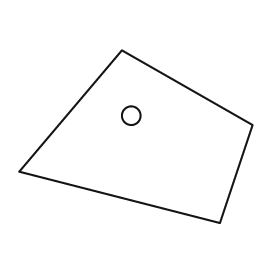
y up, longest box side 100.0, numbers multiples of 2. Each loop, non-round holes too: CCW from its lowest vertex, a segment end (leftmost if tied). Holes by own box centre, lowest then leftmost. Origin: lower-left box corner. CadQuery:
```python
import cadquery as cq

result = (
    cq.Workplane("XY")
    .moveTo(86.0, 0.0)
    .lineTo(100.0, 42.0)
    .lineTo(44.0, 74.0)
    .lineTo(0.0, 22.0)
    .close()
    .moveTo(48.0, 46.0)
    .circle(4.0)
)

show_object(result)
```